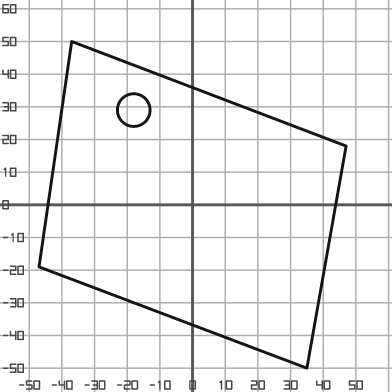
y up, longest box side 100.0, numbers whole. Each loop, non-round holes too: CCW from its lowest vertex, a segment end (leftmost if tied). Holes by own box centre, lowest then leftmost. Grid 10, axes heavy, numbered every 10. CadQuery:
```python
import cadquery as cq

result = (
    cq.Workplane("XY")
    .moveTo(35.0, -50.0)
    .lineTo(47.0, 18.0)
    .lineTo(-37.0, 50.0)
    .lineTo(-47.0, -19.0)
    .close()
    .moveTo(-18.0, 29.0)
    .circle(5.0)
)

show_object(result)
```